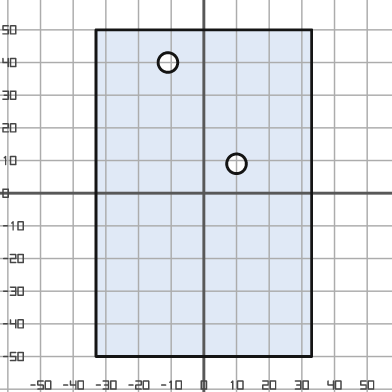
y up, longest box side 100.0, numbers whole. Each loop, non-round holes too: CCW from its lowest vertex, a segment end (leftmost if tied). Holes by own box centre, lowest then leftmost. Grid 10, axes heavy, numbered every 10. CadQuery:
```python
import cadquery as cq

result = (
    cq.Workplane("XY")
    .moveTo(-33.0, -50.0)
    .lineTo(33.0, -50.0)
    .lineTo(33.0, 50.0)
    .lineTo(-33.0, 50.0)
    .close()
    .moveTo(10.0, 9.0)
    .circle(3.0)
    .moveTo(-11.0, 40.0)
    .circle(3.0)
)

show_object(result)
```